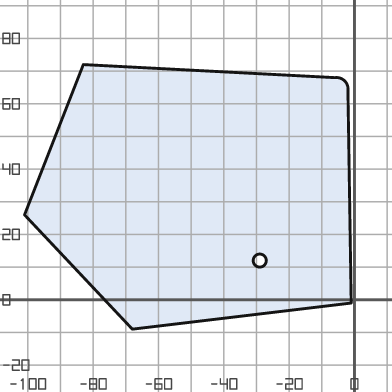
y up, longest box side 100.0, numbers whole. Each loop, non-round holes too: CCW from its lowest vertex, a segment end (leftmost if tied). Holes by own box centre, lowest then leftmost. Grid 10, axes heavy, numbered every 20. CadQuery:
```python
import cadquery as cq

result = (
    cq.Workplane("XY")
    .moveTo(-68.0, -9.0)
    .lineTo(-1.0, -1.0)
    .lineTo(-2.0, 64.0)
    .threePointArc((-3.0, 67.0), (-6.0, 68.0))
    .lineTo(-83.0, 72.0)
    .lineTo(-101.0, 26.0)
    .close()
    .moveTo(-29.0, 12.0)
    .circle(2.0)
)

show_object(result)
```